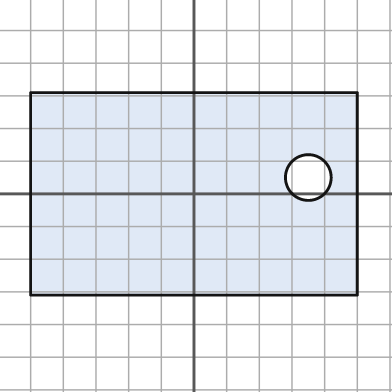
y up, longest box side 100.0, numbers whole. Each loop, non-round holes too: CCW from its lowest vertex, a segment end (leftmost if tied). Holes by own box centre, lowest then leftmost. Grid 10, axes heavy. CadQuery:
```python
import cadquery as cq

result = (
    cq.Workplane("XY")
    .moveTo(-50.0, -31.0)
    .lineTo(50.0, -31.0)
    .lineTo(50.0, 31.0)
    .lineTo(-50.0, 31.0)
    .close()
    .moveTo(35.0, 5.0)
    .circle(7.0)
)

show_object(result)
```